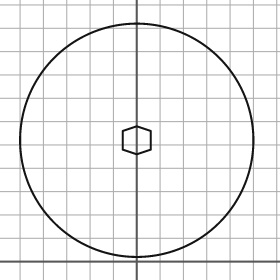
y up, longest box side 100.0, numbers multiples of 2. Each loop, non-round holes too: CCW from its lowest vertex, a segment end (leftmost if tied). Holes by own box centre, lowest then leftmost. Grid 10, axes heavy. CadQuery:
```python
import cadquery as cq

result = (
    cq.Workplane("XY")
    .moveTo(0.0, 52.0)
    .circle(50.0)
    .moveTo(0.0, 46.0)
    .lineTo(6.0, 48.0)
    .lineTo(6.0, 56.0)
    .lineTo(0.0, 58.0)
    .lineTo(-6.0, 56.0)
    .lineTo(-6.0, 48.0)
    .close()
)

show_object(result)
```